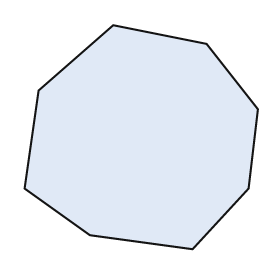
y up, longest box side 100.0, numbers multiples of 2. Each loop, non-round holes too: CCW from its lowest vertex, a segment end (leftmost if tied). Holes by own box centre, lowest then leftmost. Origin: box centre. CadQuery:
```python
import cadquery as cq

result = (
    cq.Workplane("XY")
    .moveTo(22.0, -48.0)
    .lineTo(46.0, -22.0)
    .lineTo(50.0, 12.0)
    .lineTo(28.0, 40.0)
    .lineTo(-12.0, 48.0)
    .lineTo(-44.0, 20.0)
    .lineTo(-50.0, -22.0)
    .lineTo(-22.0, -42.0)
    .close()
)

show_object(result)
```